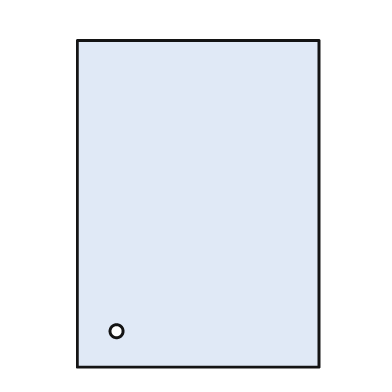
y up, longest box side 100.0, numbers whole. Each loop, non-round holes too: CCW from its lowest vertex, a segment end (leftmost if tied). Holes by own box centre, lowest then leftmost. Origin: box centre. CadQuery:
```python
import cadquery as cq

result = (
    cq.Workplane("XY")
    .moveTo(-37.0, -50.0)
    .lineTo(37.0, -50.0)
    .lineTo(37.0, 50.0)
    .lineTo(-37.0, 50.0)
    .close()
    .moveTo(-25.0, -39.0)
    .circle(2.0)
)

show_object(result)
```